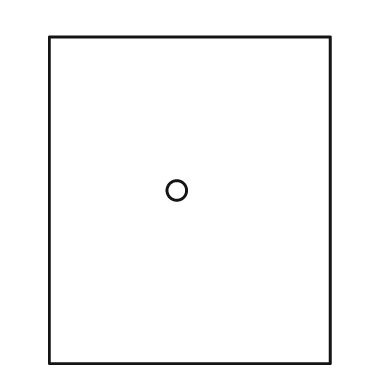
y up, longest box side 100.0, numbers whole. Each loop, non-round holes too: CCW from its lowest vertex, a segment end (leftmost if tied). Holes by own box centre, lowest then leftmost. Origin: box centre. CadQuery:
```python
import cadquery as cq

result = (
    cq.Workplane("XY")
    .moveTo(-43.0, -50.0)
    .lineTo(43.0, -50.0)
    .lineTo(43.0, 50.0)
    .lineTo(-43.0, 50.0)
    .close()
    .moveTo(-4.0, 3.0)
    .circle(3.0)
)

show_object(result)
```